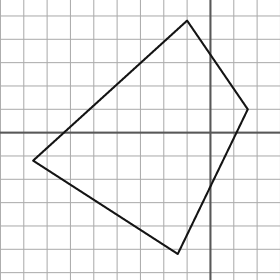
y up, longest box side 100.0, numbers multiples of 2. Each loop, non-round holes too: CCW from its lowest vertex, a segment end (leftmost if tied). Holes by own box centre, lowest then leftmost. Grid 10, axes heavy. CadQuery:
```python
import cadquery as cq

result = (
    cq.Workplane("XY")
    .moveTo(-14.0, -52.0)
    .lineTo(16.0, 10.0)
    .lineTo(-10.0, 48.0)
    .lineTo(-76.0, -12.0)
    .close()
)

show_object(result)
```